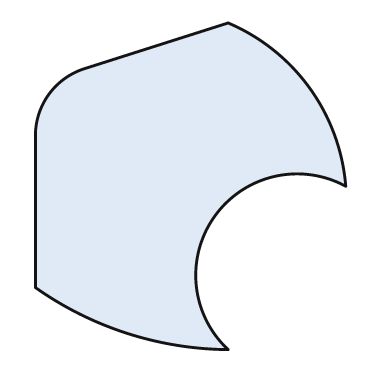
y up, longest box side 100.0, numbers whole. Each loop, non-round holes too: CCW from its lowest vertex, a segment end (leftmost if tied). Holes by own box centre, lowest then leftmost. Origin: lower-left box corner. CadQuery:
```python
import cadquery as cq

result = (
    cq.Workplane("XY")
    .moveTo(59.0, 0.0)
    .threePointArc((55.0, 41.0), (95.0, 50.0))
    .threePointArc((84.0, 80.0), (59.0, 100.0))
    .lineTo(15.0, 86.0)
    .threePointArc((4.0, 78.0), (0.0, 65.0))
    .lineTo(0.0, 19.0)
    .threePointArc((28.0, 5.0), (59.0, 0.0))
    .close()
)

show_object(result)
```